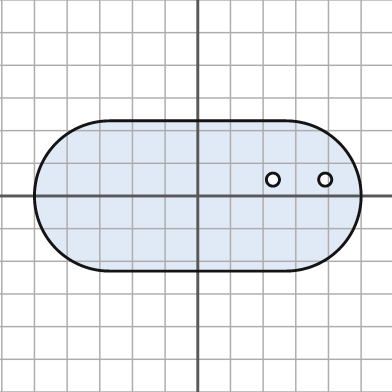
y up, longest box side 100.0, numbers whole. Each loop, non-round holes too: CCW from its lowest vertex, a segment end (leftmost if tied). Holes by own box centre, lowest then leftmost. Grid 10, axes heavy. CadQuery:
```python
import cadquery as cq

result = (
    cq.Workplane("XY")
    .moveTo(-27.0, -23.0)
    .lineTo(27.0, -23.0)
    .threePointArc((50.0, 0.0), (27.0, 23.0))
    .lineTo(-27.0, 23.0)
    .threePointArc((-50.0, 0.0), (-27.0, -23.0))
    .close()
    .moveTo(23.0, 5.0)
    .circle(2.0)
    .moveTo(39.0, 5.0)
    .circle(2.0)
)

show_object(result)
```